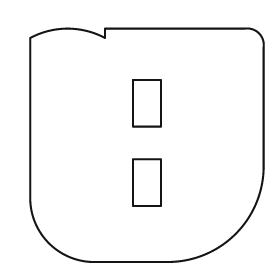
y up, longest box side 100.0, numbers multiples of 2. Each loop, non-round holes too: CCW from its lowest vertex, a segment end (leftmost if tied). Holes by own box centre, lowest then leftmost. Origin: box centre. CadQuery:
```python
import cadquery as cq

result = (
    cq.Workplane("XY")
    .moveTo(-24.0, -50.0)
    .lineTo(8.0, -50.0)
    .threePointArc((38.0, -38.0), (50.0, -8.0))
    .lineTo(50.0, 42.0)
    .threePointArc((48.0, 48.0), (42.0, 50.0))
    .lineTo(-18.0, 50.0)
    .lineTo(-18.0, 46.0)
    .threePointArc((-34.0, 50.0), (-50.0, 46.0))
    .lineTo(-50.0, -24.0)
    .threePointArc((-42.0, -42.0), (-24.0, -50.0))
    .close()
    .moveTo(-6.0, -26.0)
    .lineTo(6.0, -26.0)
    .lineTo(6.0, -6.0)
    .lineTo(-6.0, -6.0)
    .close()
    .moveTo(-6.0, 8.0)
    .lineTo(6.0, 8.0)
    .lineTo(6.0, 28.0)
    .lineTo(-6.0, 28.0)
    .close()
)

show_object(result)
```